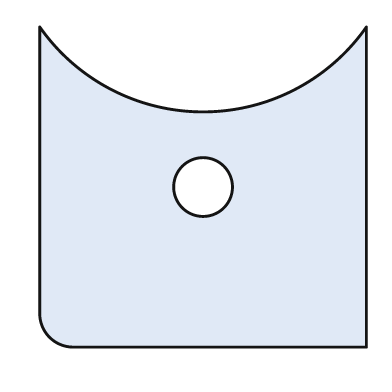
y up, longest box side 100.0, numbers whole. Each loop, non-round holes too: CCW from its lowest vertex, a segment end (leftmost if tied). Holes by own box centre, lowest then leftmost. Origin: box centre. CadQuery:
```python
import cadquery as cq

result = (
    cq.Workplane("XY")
    .moveTo(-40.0, -49.0)
    .lineTo(50.0, -49.0)
    .lineTo(50.0, 49.0)
    .threePointArc((0.0, 23.0), (-50.0, 49.0))
    .lineTo(-50.0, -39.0)
    .threePointArc((-47.0, -46.0), (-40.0, -49.0))
    .close()
    .moveTo(0.0, 0.0)
    .circle(9.0)
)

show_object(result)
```